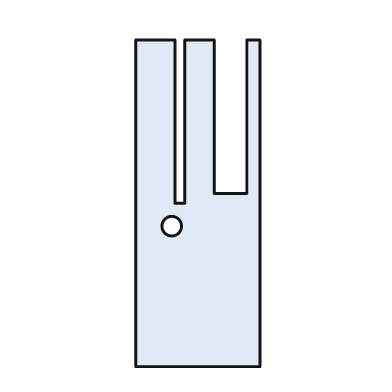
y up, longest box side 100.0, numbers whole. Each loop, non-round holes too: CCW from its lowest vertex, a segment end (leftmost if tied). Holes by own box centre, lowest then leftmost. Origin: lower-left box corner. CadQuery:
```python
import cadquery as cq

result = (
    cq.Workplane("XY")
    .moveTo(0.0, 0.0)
    .lineTo(38.0, 0.0)
    .lineTo(38.0, 100.0)
    .lineTo(34.0, 100.0)
    .lineTo(34.0, 53.0)
    .lineTo(24.0, 53.0)
    .lineTo(24.0, 100.0)
    .lineTo(15.0, 100.0)
    .lineTo(15.0, 50.0)
    .lineTo(12.0, 50.0)
    .lineTo(12.0, 100.0)
    .lineTo(0.0, 100.0)
    .close()
    .moveTo(11.0, 43.0)
    .circle(3.0)
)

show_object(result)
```